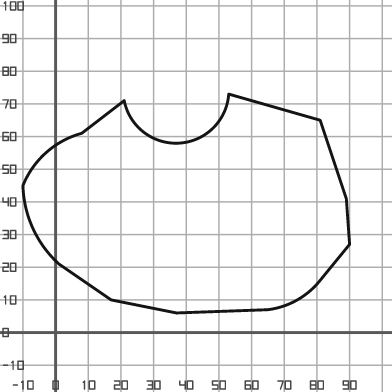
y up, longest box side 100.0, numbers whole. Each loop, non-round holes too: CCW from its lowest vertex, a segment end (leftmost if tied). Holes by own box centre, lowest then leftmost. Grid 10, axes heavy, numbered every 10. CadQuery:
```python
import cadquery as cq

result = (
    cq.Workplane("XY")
    .moveTo(37.0, 6.0)
    .lineTo(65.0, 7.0)
    .threePointArc((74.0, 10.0), (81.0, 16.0))
    .lineTo(90.0, 27.0)
    .lineTo(89.0, 41.0)
    .lineTo(81.0, 65.0)
    .lineTo(53.0, 73.0)
    .threePointArc((38.0, 58.0), (21.0, 71.0))
    .lineTo(8.0, 61.0)
    .threePointArc((-3.0, 55.0), (-10.0, 45.0))
    .threePointArc((-7.0, 32.0), (1.0, 21.0))
    .lineTo(17.0, 10.0)
    .close()
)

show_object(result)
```